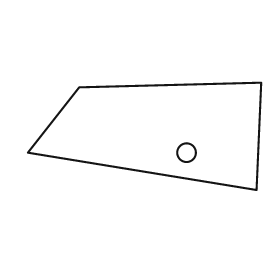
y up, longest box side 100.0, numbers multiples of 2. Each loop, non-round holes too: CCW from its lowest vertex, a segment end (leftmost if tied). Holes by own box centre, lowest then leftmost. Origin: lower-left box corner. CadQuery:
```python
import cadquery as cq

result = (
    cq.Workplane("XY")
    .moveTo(98.0, 0.0)
    .lineTo(100.0, 46.0)
    .lineTo(22.0, 44.0)
    .lineTo(0.0, 16.0)
    .close()
    .moveTo(68.0, 16.0)
    .circle(4.0)
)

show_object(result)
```